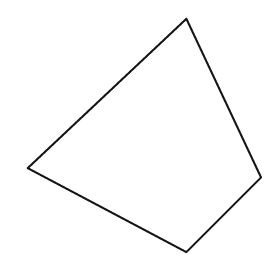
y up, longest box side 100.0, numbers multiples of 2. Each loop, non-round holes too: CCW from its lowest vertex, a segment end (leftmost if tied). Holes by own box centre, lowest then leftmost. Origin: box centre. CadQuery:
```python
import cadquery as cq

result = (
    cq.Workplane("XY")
    .moveTo(18.0, -50.0)
    .lineTo(50.0, -18.0)
    .lineTo(18.0, 50.0)
    .lineTo(-50.0, -14.0)
    .close()
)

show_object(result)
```